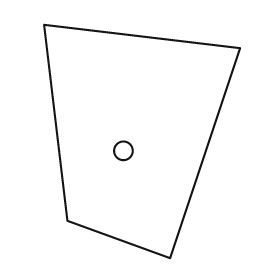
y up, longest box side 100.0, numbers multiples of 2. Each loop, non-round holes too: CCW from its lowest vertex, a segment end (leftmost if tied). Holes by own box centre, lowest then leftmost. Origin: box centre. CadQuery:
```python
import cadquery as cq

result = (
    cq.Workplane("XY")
    .moveTo(12.0, -50.0)
    .lineTo(42.0, 40.0)
    .lineTo(-42.0, 50.0)
    .lineTo(-32.0, -34.0)
    .close()
    .moveTo(-8.0, -4.0)
    .circle(4.0)
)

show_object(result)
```